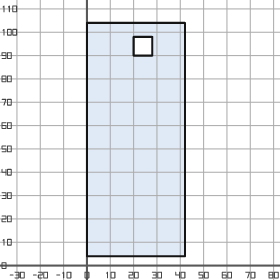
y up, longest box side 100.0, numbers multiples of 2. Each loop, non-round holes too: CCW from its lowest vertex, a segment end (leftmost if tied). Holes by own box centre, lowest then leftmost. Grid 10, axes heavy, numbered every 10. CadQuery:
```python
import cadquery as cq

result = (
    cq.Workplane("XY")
    .moveTo(0.0, 4.0)
    .lineTo(42.0, 4.0)
    .lineTo(42.0, 104.0)
    .lineTo(0.0, 104.0)
    .close()
    .moveTo(20.0, 90.0)
    .lineTo(28.0, 90.0)
    .lineTo(28.0, 98.0)
    .lineTo(20.0, 98.0)
    .close()
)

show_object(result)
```